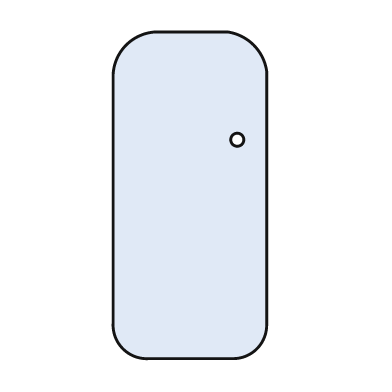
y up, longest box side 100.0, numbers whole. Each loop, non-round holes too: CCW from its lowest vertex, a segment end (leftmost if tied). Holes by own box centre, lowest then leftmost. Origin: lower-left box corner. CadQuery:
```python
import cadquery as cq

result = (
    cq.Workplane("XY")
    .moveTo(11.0, 0.0)
    .lineTo(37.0, 0.0)
    .threePointArc((44.0, 3.0), (47.0, 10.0))
    .lineTo(47.0, 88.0)
    .threePointArc((43.0, 96.0), (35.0, 100.0))
    .lineTo(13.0, 100.0)
    .threePointArc((4.0, 96.0), (0.0, 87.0))
    .lineTo(0.0, 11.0)
    .threePointArc((3.0, 3.0), (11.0, 0.0))
    .close()
    .moveTo(38.0, 67.0)
    .circle(2.0)
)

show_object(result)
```